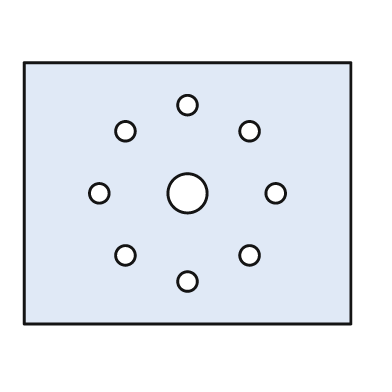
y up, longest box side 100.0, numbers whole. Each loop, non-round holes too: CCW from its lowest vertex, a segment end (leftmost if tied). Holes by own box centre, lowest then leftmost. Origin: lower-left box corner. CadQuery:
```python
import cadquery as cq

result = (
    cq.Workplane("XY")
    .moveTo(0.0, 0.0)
    .lineTo(100.0, 0.0)
    .lineTo(100.0, 80.0)
    .lineTo(0.0, 80.0)
    .close()
    .moveTo(50.0, 13.0)
    .circle(3.0)
    .moveTo(31.0, 21.0)
    .circle(3.0)
    .moveTo(69.0, 21.0)
    .circle(3.0)
    .moveTo(23.0, 40.0)
    .circle(3.0)
    .moveTo(50.0, 40.0)
    .circle(6.0)
    .moveTo(77.0, 40.0)
    .circle(3.0)
    .moveTo(31.0, 59.0)
    .circle(3.0)
    .moveTo(69.0, 59.0)
    .circle(3.0)
    .moveTo(50.0, 67.0)
    .circle(3.0)
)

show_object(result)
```